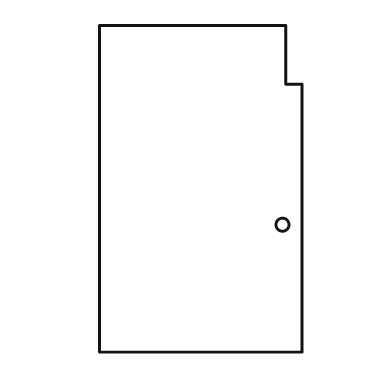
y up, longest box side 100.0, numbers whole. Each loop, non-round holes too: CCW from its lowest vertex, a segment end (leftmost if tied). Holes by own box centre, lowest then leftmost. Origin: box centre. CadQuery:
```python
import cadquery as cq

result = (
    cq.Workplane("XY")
    .moveTo(-31.0, -50.0)
    .lineTo(31.0, -50.0)
    .lineTo(31.0, 32.0)
    .lineTo(26.0, 32.0)
    .lineTo(26.0, 50.0)
    .lineTo(-31.0, 50.0)
    .close()
    .moveTo(25.0, -11.0)
    .circle(2.0)
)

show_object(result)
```